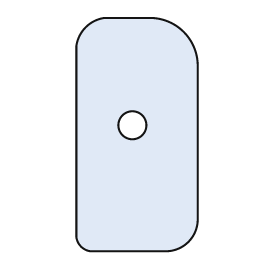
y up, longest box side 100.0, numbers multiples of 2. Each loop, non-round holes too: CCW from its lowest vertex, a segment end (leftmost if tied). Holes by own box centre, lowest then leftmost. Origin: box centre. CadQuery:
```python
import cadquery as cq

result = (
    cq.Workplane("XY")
    .moveTo(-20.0, -50.0)
    .lineTo(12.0, -50.0)
    .threePointArc((22.0, -46.0), (26.0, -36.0))
    .lineTo(26.0, 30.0)
    .threePointArc((20.0, 44.0), (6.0, 50.0))
    .lineTo(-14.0, 50.0)
    .threePointArc((-22.0, 46.0), (-26.0, 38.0))
    .lineTo(-26.0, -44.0)
    .threePointArc((-24.0, -48.0), (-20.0, -50.0))
    .close()
    .moveTo(-2.0, 4.0)
    .circle(6.0)
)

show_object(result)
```